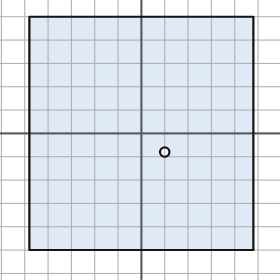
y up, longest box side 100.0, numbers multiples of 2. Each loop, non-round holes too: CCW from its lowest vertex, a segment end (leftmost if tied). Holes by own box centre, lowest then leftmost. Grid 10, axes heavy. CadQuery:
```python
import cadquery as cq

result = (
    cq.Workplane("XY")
    .moveTo(-48.0, -50.0)
    .lineTo(48.0, -50.0)
    .lineTo(48.0, 50.0)
    .lineTo(-48.0, 50.0)
    .close()
    .moveTo(10.0, -8.0)
    .circle(2.0)
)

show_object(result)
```